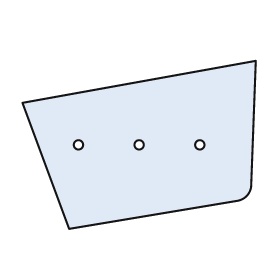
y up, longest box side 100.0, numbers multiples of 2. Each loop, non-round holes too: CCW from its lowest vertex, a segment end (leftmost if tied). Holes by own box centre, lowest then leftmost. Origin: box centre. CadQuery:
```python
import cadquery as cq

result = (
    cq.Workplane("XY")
    .moveTo(-30.0, -36.0)
    .lineTo(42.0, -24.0)
    .threePointArc((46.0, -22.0), (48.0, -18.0))
    .lineTo(50.0, 36.0)
    .lineTo(-50.0, 18.0)
    .close()
    .moveTo(-26.0, 0.0)
    .circle(2.0)
    .moveTo(0.0, 0.0)
    .circle(2.0)
    .moveTo(26.0, 0.0)
    .circle(2.0)
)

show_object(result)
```